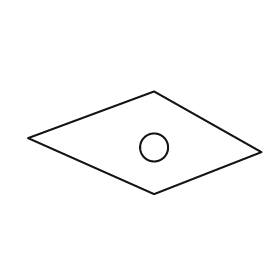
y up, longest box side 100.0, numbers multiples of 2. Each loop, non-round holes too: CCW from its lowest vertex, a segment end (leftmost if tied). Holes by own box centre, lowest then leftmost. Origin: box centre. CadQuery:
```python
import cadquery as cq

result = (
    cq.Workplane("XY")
    .moveTo(4.0, -22.0)
    .lineTo(50.0, -4.0)
    .lineTo(4.0, 22.0)
    .lineTo(-50.0, 2.0)
    .close()
    .moveTo(4.0, -2.0)
    .circle(6.0)
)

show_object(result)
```